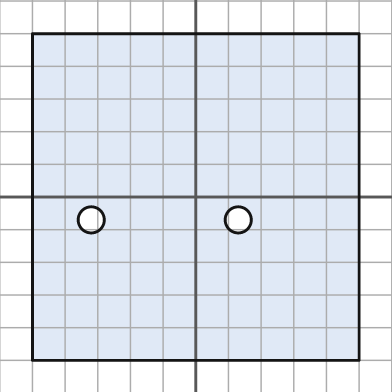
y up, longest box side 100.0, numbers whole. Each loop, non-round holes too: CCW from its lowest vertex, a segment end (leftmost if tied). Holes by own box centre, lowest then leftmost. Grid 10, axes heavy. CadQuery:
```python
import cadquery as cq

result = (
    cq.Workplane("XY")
    .moveTo(-50.0, -50.0)
    .lineTo(50.0, -50.0)
    .lineTo(50.0, 50.0)
    .lineTo(-50.0, 50.0)
    .close()
    .moveTo(-32.0, -7.0)
    .circle(4.0)
    .moveTo(13.0, -7.0)
    .circle(4.0)
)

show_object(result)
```